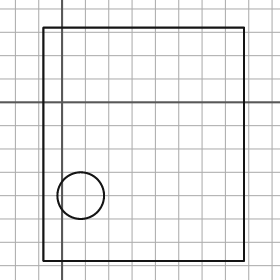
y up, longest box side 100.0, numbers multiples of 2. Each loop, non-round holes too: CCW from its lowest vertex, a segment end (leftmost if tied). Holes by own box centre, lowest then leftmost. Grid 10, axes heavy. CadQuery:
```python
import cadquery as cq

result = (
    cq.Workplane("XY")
    .moveTo(-8.0, -68.0)
    .lineTo(78.0, -68.0)
    .lineTo(78.0, 32.0)
    .lineTo(-8.0, 32.0)
    .close()
    .moveTo(8.0, -40.0)
    .circle(10.0)
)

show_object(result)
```